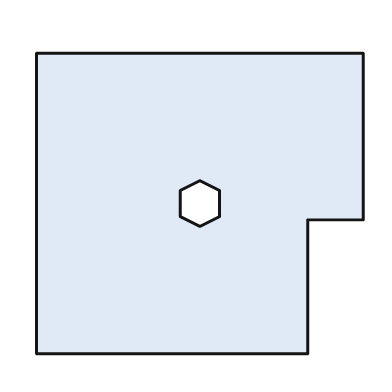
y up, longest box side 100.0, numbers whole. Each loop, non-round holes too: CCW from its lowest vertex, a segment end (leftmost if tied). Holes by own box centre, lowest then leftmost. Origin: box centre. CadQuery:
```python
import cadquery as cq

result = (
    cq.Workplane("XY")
    .moveTo(-50.0, -46.0)
    .lineTo(33.0, -46.0)
    .lineTo(33.0, -5.0)
    .lineTo(50.0, -5.0)
    .lineTo(50.0, 46.0)
    .lineTo(-50.0, 46.0)
    .close()
    .moveTo(0.0, -7.0)
    .lineTo(6.0, -4.0)
    .lineTo(6.0, 4.0)
    .lineTo(0.0, 7.0)
    .lineTo(-6.0, 4.0)
    .lineTo(-6.0, -4.0)
    .close()
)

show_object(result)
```